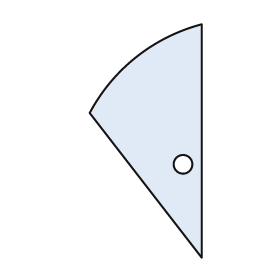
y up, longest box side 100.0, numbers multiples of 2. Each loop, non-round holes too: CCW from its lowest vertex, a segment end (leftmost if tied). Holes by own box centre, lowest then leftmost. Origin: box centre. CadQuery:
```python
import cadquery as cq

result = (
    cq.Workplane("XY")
    .moveTo(24.0, -50.0)
    .lineTo(24.0, 50.0)
    .threePointArc((-4.0, 36.0), (-24.0, 12.0))
    .close()
    .moveTo(16.0, -10.0)
    .circle(4.0)
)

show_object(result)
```